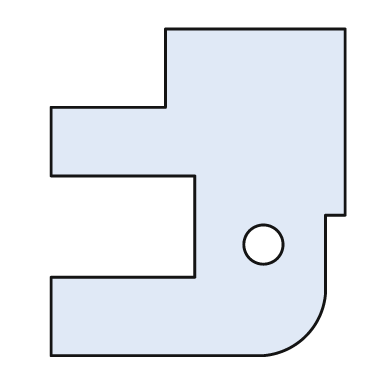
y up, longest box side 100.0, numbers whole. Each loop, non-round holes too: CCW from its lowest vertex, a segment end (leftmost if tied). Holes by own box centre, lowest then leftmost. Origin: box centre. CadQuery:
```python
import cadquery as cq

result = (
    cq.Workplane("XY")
    .moveTo(-45.0, -50.0)
    .lineTo(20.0, -50.0)
    .threePointArc((33.0, -44.0), (39.0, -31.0))
    .lineTo(39.0, -7.0)
    .lineTo(45.0, -7.0)
    .lineTo(45.0, 50.0)
    .lineTo(-10.0, 50.0)
    .lineTo(-10.0, 26.0)
    .lineTo(-45.0, 26.0)
    .lineTo(-45.0, 5.0)
    .lineTo(-1.0, 5.0)
    .lineTo(-1.0, -26.0)
    .lineTo(-45.0, -26.0)
    .close()
    .moveTo(20.0, -16.0)
    .circle(6.0)
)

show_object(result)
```